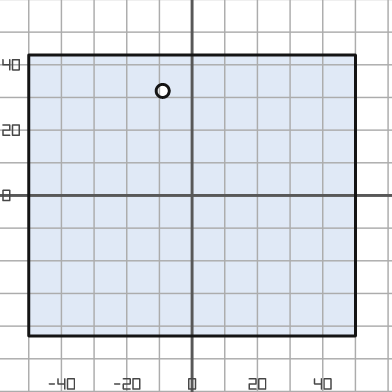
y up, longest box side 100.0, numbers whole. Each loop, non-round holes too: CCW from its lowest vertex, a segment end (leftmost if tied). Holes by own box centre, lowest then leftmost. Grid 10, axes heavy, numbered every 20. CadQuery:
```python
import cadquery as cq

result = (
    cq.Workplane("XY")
    .moveTo(-50.0, -43.0)
    .lineTo(50.0, -43.0)
    .lineTo(50.0, 43.0)
    .lineTo(-50.0, 43.0)
    .close()
    .moveTo(-9.0, 32.0)
    .circle(2.0)
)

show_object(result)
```